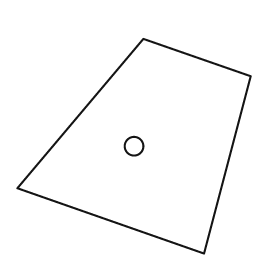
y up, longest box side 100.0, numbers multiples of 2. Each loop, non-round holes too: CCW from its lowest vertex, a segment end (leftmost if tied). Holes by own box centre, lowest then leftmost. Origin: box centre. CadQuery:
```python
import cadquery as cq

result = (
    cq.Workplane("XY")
    .moveTo(30.0, -46.0)
    .lineTo(50.0, 30.0)
    .lineTo(4.0, 46.0)
    .lineTo(-50.0, -18.0)
    .close()
    .moveTo(0.0, 0.0)
    .circle(4.0)
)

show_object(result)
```